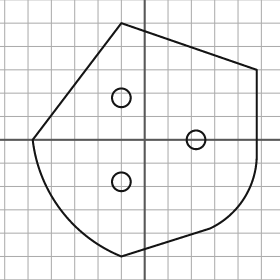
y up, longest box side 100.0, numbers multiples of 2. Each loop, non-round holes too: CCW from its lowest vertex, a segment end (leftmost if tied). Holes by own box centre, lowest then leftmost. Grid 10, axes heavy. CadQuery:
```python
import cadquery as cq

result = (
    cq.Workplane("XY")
    .moveTo(-10.0, -50.0)
    .lineTo(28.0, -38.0)
    .threePointArc((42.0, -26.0), (48.0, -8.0))
    .lineTo(48.0, 30.0)
    .lineTo(-10.0, 50.0)
    .lineTo(-48.0, 0.0)
    .threePointArc((-36.0, -30.0), (-10.0, -50.0))
    .close()
    .moveTo(-10.0, -18.0)
    .circle(4.0)
    .moveTo(22.0, 0.0)
    .circle(4.0)
    .moveTo(-10.0, 18.0)
    .circle(4.0)
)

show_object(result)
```